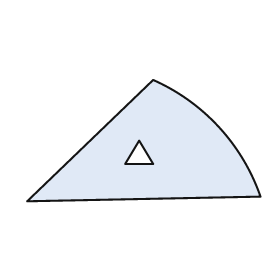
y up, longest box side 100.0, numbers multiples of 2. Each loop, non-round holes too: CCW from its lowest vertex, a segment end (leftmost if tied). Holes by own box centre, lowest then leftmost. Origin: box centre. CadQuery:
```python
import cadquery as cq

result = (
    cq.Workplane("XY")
    .moveTo(-50.0, -26.0)
    .lineTo(50.0, -24.0)
    .threePointArc((32.0, 6.0), (4.0, 26.0))
    .close()
    .moveTo(-8.0, -10.0)
    .lineTo(4.0, -10.0)
    .lineTo(-2.0, 0.0)
    .close()
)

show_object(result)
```